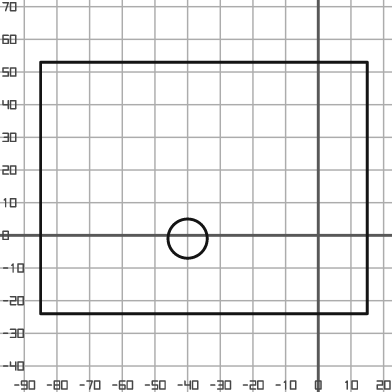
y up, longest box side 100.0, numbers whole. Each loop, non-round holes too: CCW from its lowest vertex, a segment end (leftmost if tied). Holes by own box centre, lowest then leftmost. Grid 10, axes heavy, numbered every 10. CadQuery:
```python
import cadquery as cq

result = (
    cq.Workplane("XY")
    .moveTo(-85.0, -24.0)
    .lineTo(15.0, -24.0)
    .lineTo(15.0, 53.0)
    .lineTo(-85.0, 53.0)
    .close()
    .moveTo(-40.0, -1.0)
    .circle(6.0)
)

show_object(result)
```